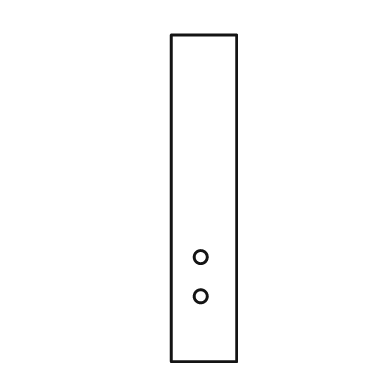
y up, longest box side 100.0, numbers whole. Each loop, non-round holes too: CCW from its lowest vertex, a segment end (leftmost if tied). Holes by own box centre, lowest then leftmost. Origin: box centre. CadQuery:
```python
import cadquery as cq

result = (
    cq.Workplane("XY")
    .moveTo(-10.0, -50.0)
    .lineTo(10.0, -50.0)
    .lineTo(10.0, 50.0)
    .lineTo(-10.0, 50.0)
    .close()
    .moveTo(-1.0, -30.0)
    .circle(2.0)
    .moveTo(-1.0, -18.0)
    .circle(2.0)
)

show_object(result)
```